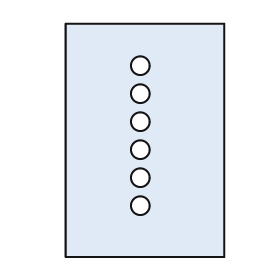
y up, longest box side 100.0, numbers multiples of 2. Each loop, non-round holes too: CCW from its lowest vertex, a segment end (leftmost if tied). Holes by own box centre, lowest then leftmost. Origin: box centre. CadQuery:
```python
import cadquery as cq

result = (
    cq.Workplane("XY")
    .moveTo(-34.0, -50.0)
    .lineTo(34.0, -50.0)
    .lineTo(34.0, 50.0)
    .lineTo(-34.0, 50.0)
    .close()
    .moveTo(-2.0, -28.0)
    .circle(4.0)
    .moveTo(-2.0, -16.0)
    .circle(4.0)
    .moveTo(-2.0, -4.0)
    .circle(4.0)
    .moveTo(-2.0, 8.0)
    .circle(4.0)
    .moveTo(-2.0, 20.0)
    .circle(4.0)
    .moveTo(-2.0, 32.0)
    .circle(4.0)
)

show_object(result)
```